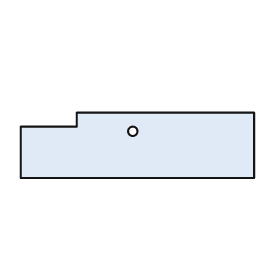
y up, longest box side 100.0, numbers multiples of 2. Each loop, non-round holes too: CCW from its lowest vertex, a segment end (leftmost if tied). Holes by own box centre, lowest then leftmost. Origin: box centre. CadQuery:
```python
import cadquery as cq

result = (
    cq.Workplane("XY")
    .moveTo(-50.0, -14.0)
    .lineTo(50.0, -14.0)
    .lineTo(50.0, 14.0)
    .lineTo(-26.0, 14.0)
    .lineTo(-26.0, 8.0)
    .lineTo(-50.0, 8.0)
    .close()
    .moveTo(-2.0, 6.0)
    .circle(2.0)
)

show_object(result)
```